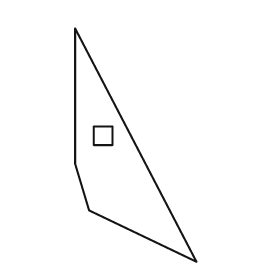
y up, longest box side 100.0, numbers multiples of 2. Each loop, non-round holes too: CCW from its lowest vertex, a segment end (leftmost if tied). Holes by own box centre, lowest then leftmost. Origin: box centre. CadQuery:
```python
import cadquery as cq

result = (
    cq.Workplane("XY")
    .moveTo(26.0, -50.0)
    .lineTo(-26.0, 50.0)
    .lineTo(-26.0, -8.0)
    .lineTo(-20.0, -28.0)
    .close()
    .moveTo(-18.0, 0.0)
    .lineTo(-10.0, 0.0)
    .lineTo(-10.0, 8.0)
    .lineTo(-18.0, 8.0)
    .close()
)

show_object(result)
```